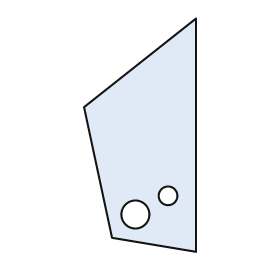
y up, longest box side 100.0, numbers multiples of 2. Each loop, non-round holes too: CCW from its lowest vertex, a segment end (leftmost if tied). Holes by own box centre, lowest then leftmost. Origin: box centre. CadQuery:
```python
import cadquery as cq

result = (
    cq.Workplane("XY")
    .moveTo(24.0, -50.0)
    .lineTo(24.0, 50.0)
    .lineTo(-24.0, 12.0)
    .lineTo(-12.0, -44.0)
    .close()
    .moveTo(-2.0, -34.0)
    .circle(6.0)
    .moveTo(12.0, -26.0)
    .circle(4.0)
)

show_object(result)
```